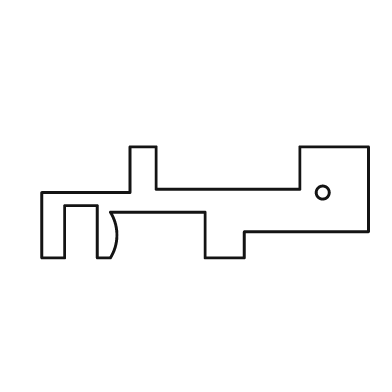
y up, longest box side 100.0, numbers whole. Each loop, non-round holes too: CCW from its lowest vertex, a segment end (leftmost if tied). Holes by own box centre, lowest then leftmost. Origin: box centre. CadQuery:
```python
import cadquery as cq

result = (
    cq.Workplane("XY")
    .moveTo(-50.0, -17.0)
    .lineTo(-43.0, -17.0)
    .lineTo(-43.0, -1.0)
    .lineTo(-33.0, -1.0)
    .lineTo(-33.0, -17.0)
    .lineTo(-29.0, -17.0)
    .threePointArc((-27.0, -10.0), (-29.0, -3.0))
    .lineTo(0.0, -3.0)
    .lineTo(0.0, -17.0)
    .lineTo(12.0, -17.0)
    .lineTo(12.0, -9.0)
    .lineTo(50.0, -9.0)
    .lineTo(50.0, 17.0)
    .lineTo(29.0, 17.0)
    .lineTo(29.0, 4.0)
    .lineTo(-15.0, 4.0)
    .lineTo(-15.0, 17.0)
    .lineTo(-23.0, 17.0)
    .lineTo(-23.0, 3.0)
    .lineTo(-50.0, 3.0)
    .close()
    .moveTo(36.0, 3.0)
    .circle(2.0)
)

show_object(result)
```